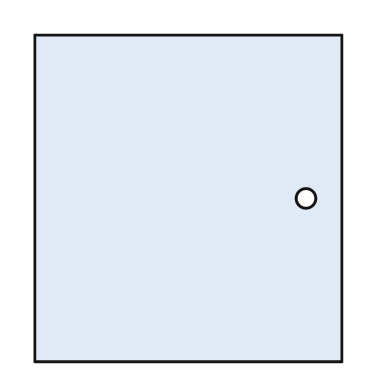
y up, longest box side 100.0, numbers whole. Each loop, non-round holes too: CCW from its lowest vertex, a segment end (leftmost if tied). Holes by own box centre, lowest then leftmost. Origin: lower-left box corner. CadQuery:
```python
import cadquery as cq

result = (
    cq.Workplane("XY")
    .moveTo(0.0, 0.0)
    .lineTo(94.0, 0.0)
    .lineTo(94.0, 100.0)
    .lineTo(0.0, 100.0)
    .close()
    .moveTo(83.0, 50.0)
    .circle(3.0)
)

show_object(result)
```